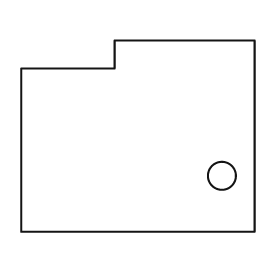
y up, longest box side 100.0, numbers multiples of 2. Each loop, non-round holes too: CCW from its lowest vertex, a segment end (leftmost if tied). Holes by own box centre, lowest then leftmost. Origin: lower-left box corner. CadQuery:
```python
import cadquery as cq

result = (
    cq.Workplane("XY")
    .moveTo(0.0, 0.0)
    .lineTo(100.0, 0.0)
    .lineTo(100.0, 82.0)
    .lineTo(40.0, 82.0)
    .lineTo(40.0, 70.0)
    .lineTo(0.0, 70.0)
    .close()
    .moveTo(86.0, 24.0)
    .circle(6.0)
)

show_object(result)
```